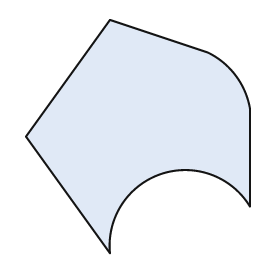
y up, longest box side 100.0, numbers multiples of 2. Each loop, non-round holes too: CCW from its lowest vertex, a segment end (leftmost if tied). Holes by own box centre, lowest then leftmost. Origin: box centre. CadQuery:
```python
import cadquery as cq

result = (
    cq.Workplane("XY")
    .moveTo(-12.0, -50.0)
    .threePointArc((10.0, -16.0), (48.0, -30.0))
    .lineTo(48.0, 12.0)
    .threePointArc((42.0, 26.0), (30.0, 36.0))
    .lineTo(-12.0, 50.0)
    .lineTo(-48.0, 0.0)
    .close()
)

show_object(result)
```